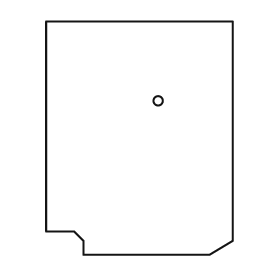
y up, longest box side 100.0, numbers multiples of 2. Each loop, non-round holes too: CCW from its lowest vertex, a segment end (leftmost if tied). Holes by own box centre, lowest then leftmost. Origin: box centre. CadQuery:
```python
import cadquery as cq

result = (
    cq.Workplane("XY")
    .moveTo(-24.0, -50.0)
    .lineTo(30.0, -50.0)
    .lineTo(40.0, -44.0)
    .lineTo(40.0, 50.0)
    .lineTo(-40.0, 50.0)
    .lineTo(-40.0, -40.0)
    .lineTo(-28.0, -40.0)
    .lineTo(-24.0, -44.0)
    .close()
    .moveTo(8.0, 16.0)
    .circle(2.0)
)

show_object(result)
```